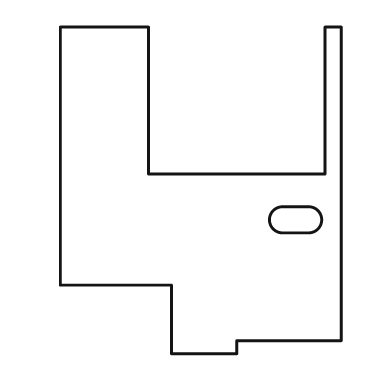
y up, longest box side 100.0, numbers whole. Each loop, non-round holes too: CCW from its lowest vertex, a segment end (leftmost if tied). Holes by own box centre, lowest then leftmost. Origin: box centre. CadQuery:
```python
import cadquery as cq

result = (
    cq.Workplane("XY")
    .moveTo(-9.0, -50.0)
    .lineTo(11.0, -50.0)
    .lineTo(11.0, -46.0)
    .lineTo(43.0, -46.0)
    .lineTo(43.0, 50.0)
    .lineTo(38.0, 50.0)
    .lineTo(38.0, 5.0)
    .lineTo(-16.0, 5.0)
    .lineTo(-16.0, 50.0)
    .lineTo(-43.0, 50.0)
    .lineTo(-43.0, -29.0)
    .lineTo(-9.0, -29.0)
    .close()
    .moveTo(25.0, -13.0)
    .lineTo(33.0, -13.0)
    .threePointArc((37.0, -9.0), (33.0, -5.0))
    .lineTo(25.0, -5.0)
    .threePointArc((21.0, -9.0), (25.0, -13.0))
    .close()
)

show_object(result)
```